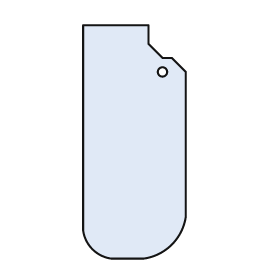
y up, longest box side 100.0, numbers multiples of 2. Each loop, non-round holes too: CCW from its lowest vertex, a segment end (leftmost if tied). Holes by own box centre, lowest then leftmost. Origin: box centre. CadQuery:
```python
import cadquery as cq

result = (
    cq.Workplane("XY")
    .moveTo(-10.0, -50.0)
    .lineTo(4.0, -50.0)
    .threePointArc((16.0, -44.0), (22.0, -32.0))
    .lineTo(22.0, 30.0)
    .lineTo(16.0, 36.0)
    .lineTo(12.0, 36.0)
    .lineTo(6.0, 42.0)
    .lineTo(6.0, 50.0)
    .lineTo(-22.0, 50.0)
    .lineTo(-22.0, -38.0)
    .threePointArc((-18.0, -46.0), (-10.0, -50.0))
    .close()
    .moveTo(12.0, 30.0)
    .circle(2.0)
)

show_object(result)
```